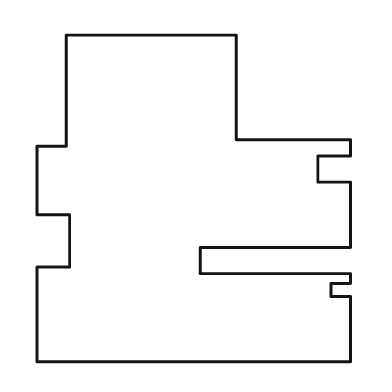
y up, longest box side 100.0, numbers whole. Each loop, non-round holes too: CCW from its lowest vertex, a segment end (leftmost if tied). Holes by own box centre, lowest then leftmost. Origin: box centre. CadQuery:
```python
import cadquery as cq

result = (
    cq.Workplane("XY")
    .moveTo(-48.0, -50.0)
    .lineTo(48.0, -50.0)
    .lineTo(48.0, -30.0)
    .lineTo(42.0, -30.0)
    .lineTo(42.0, -26.0)
    .lineTo(48.0, -26.0)
    .lineTo(48.0, -23.0)
    .lineTo(2.0, -23.0)
    .lineTo(2.0, -15.0)
    .lineTo(48.0, -15.0)
    .lineTo(48.0, 5.0)
    .lineTo(38.0, 5.0)
    .lineTo(38.0, 13.0)
    .lineTo(48.0, 13.0)
    .lineTo(48.0, 18.0)
    .lineTo(13.0, 18.0)
    .lineTo(13.0, 50.0)
    .lineTo(-39.0, 50.0)
    .lineTo(-39.0, 16.0)
    .lineTo(-48.0, 16.0)
    .lineTo(-48.0, -5.0)
    .lineTo(-38.0, -5.0)
    .lineTo(-38.0, -21.0)
    .lineTo(-48.0, -21.0)
    .close()
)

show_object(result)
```